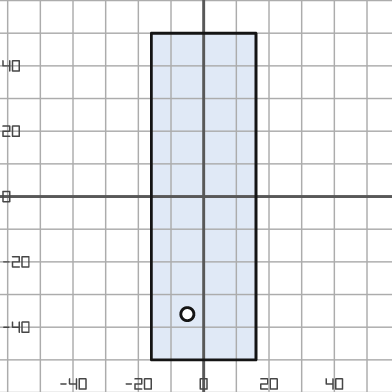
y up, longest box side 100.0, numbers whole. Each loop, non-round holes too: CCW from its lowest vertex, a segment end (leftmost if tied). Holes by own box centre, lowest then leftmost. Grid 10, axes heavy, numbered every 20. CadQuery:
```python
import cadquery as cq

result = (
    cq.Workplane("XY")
    .moveTo(-16.0, -50.0)
    .lineTo(16.0, -50.0)
    .lineTo(16.0, 50.0)
    .lineTo(-16.0, 50.0)
    .close()
    .moveTo(-5.0, -36.0)
    .circle(2.0)
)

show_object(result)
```